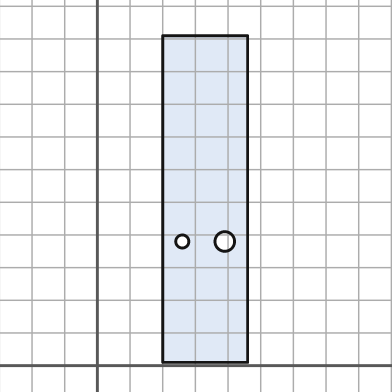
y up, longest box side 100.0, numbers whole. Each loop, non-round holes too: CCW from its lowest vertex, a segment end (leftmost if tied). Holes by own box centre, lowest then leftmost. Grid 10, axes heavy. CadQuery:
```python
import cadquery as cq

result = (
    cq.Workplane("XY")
    .moveTo(20.0, 1.0)
    .lineTo(46.0, 1.0)
    .lineTo(46.0, 101.0)
    .lineTo(20.0, 101.0)
    .close()
    .moveTo(26.0, 38.0)
    .circle(2.0)
    .moveTo(39.0, 38.0)
    .circle(3.0)
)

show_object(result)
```